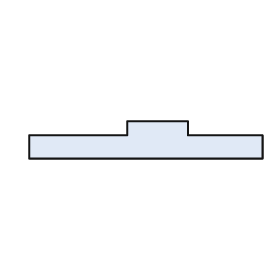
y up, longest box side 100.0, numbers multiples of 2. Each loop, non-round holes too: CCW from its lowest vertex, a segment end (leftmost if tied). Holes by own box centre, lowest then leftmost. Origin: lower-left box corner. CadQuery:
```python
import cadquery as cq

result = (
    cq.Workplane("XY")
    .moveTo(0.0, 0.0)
    .lineTo(100.0, 0.0)
    .lineTo(100.0, 10.0)
    .lineTo(68.0, 10.0)
    .lineTo(68.0, 16.0)
    .lineTo(42.0, 16.0)
    .lineTo(42.0, 10.0)
    .lineTo(0.0, 10.0)
    .close()
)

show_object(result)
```